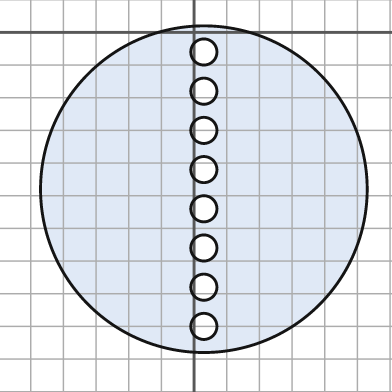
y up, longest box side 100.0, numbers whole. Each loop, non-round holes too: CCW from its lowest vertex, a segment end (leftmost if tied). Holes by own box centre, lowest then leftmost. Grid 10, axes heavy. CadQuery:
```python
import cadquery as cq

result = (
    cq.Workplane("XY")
    .moveTo(3.0, -48.0)
    .circle(50.0)
    .moveTo(3.0, -90.0)
    .circle(4.0)
    .moveTo(3.0, -78.0)
    .circle(4.0)
    .moveTo(3.0, -66.0)
    .circle(4.0)
    .moveTo(3.0, -54.0)
    .circle(4.0)
    .moveTo(3.0, -42.0)
    .circle(4.0)
    .moveTo(3.0, -30.0)
    .circle(4.0)
    .moveTo(3.0, -18.0)
    .circle(4.0)
    .moveTo(3.0, -6.0)
    .circle(4.0)
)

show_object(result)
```